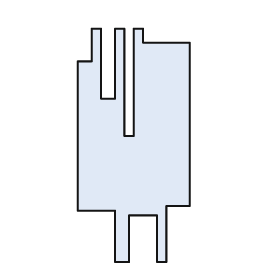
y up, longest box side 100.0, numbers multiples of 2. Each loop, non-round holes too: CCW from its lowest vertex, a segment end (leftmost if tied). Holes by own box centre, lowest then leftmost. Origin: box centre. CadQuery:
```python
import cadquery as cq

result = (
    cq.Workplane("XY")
    .moveTo(-8.0, -50.0)
    .lineTo(-2.0, -50.0)
    .lineTo(-2.0, -30.0)
    .lineTo(10.0, -30.0)
    .lineTo(10.0, -50.0)
    .lineTo(14.0, -50.0)
    .lineTo(14.0, -26.0)
    .lineTo(24.0, -26.0)
    .lineTo(24.0, 44.0)
    .lineTo(4.0, 44.0)
    .lineTo(4.0, 50.0)
    .lineTo(0.0, 50.0)
    .lineTo(0.0, 4.0)
    .lineTo(-4.0, 4.0)
    .lineTo(-4.0, 50.0)
    .lineTo(-8.0, 50.0)
    .lineTo(-8.0, 20.0)
    .lineTo(-14.0, 20.0)
    .lineTo(-14.0, 50.0)
    .lineTo(-18.0, 50.0)
    .lineTo(-18.0, 36.0)
    .lineTo(-24.0, 36.0)
    .lineTo(-24.0, -28.0)
    .lineTo(-8.0, -28.0)
    .close()
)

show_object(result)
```